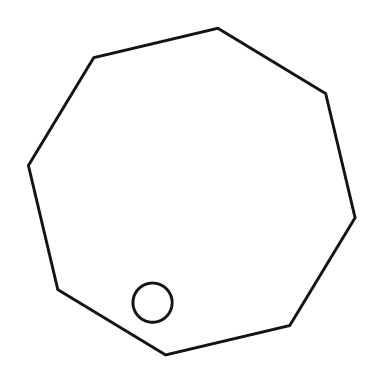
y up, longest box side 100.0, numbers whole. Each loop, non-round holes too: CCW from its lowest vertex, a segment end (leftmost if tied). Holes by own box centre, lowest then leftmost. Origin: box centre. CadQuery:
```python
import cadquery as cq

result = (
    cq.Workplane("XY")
    .moveTo(-8.0, -50.0)
    .lineTo(30.0, -41.0)
    .lineTo(50.0, -8.0)
    .lineTo(41.0, 30.0)
    .lineTo(8.0, 50.0)
    .lineTo(-30.0, 41.0)
    .lineTo(-50.0, 8.0)
    .lineTo(-41.0, -30.0)
    .close()
    .moveTo(-12.0, -34.0)
    .circle(6.0)
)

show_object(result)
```